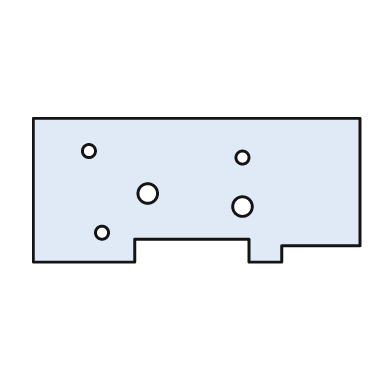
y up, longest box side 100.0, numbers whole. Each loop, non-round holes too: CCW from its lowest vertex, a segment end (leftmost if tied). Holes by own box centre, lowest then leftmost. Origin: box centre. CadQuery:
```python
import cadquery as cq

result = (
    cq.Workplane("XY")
    .moveTo(-50.0, -22.0)
    .lineTo(-19.0, -22.0)
    .lineTo(-19.0, -15.0)
    .lineTo(16.0, -15.0)
    .lineTo(16.0, -22.0)
    .lineTo(26.0, -22.0)
    .lineTo(26.0, -17.0)
    .lineTo(50.0, -17.0)
    .lineTo(50.0, 22.0)
    .lineTo(-50.0, 22.0)
    .close()
    .moveTo(-29.0, -13.0)
    .circle(2.0)
    .moveTo(14.0, -5.0)
    .circle(3.0)
    .moveTo(-15.0, -1.0)
    .circle(3.0)
    .moveTo(14.0, 10.0)
    .circle(2.0)
    .moveTo(-33.0, 12.0)
    .circle(2.0)
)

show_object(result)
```